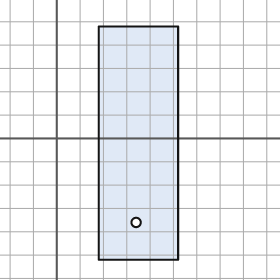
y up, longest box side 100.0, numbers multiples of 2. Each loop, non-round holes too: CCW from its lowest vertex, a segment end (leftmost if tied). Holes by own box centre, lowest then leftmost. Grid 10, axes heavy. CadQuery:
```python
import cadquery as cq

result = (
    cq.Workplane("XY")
    .moveTo(18.0, -52.0)
    .lineTo(52.0, -52.0)
    .lineTo(52.0, 48.0)
    .lineTo(18.0, 48.0)
    .close()
    .moveTo(34.0, -36.0)
    .circle(2.0)
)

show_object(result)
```